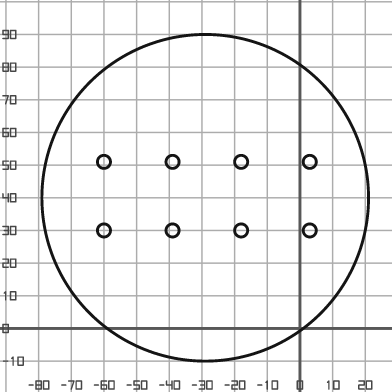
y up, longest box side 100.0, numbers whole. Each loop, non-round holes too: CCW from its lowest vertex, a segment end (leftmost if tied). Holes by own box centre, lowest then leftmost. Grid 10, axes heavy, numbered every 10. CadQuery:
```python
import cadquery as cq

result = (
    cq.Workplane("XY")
    .moveTo(-29.0, 40.0)
    .circle(50.0)
    .moveTo(-60.0, 30.0)
    .circle(2.0)
    .moveTo(-39.0, 30.0)
    .circle(2.0)
    .moveTo(-18.0, 30.0)
    .circle(2.0)
    .moveTo(3.0, 30.0)
    .circle(2.0)
    .moveTo(-60.0, 51.0)
    .circle(2.0)
    .moveTo(-39.0, 51.0)
    .circle(2.0)
    .moveTo(-18.0, 51.0)
    .circle(2.0)
    .moveTo(3.0, 51.0)
    .circle(2.0)
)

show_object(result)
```